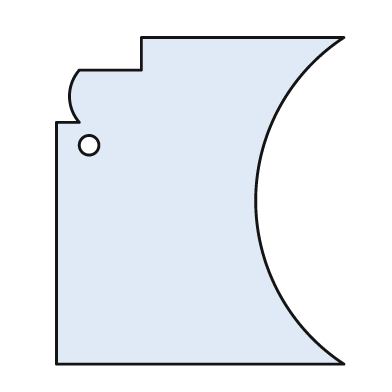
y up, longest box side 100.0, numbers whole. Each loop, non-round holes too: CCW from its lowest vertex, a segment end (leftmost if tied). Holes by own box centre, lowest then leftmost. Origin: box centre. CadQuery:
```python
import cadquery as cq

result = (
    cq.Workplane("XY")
    .moveTo(-44.0, -50.0)
    .lineTo(44.0, -50.0)
    .threePointArc((17.0, 0.0), (44.0, 50.0))
    .lineTo(-18.0, 50.0)
    .lineTo(-18.0, 40.0)
    .lineTo(-37.0, 40.0)
    .threePointArc((-40.0, 32.0), (-37.0, 24.0))
    .lineTo(-44.0, 24.0)
    .close()
    .moveTo(-34.0, 17.0)
    .circle(3.0)
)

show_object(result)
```